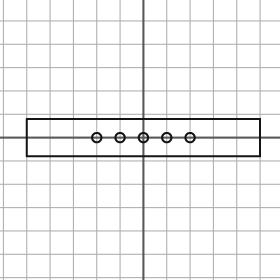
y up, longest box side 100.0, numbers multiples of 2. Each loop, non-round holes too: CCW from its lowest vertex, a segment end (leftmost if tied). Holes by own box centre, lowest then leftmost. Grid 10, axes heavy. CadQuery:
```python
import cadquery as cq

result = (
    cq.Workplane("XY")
    .moveTo(-50.0, -8.0)
    .lineTo(50.0, -8.0)
    .lineTo(50.0, 8.0)
    .lineTo(-50.0, 8.0)
    .close()
    .moveTo(-20.0, 0.0)
    .circle(2.0)
    .moveTo(-10.0, 0.0)
    .circle(2.0)
    .moveTo(0.0, 0.0)
    .circle(2.0)
    .moveTo(10.0, 0.0)
    .circle(2.0)
    .moveTo(20.0, 0.0)
    .circle(2.0)
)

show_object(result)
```